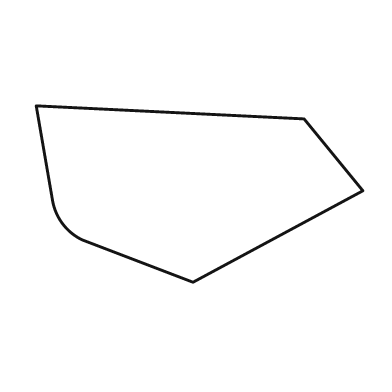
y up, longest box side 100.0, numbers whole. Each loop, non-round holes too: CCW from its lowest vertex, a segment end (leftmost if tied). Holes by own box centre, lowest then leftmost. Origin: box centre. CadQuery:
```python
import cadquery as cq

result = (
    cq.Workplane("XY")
    .moveTo(-2.0, -27.0)
    .lineTo(50.0, 1.0)
    .lineTo(32.0, 23.0)
    .lineTo(-50.0, 27.0)
    .lineTo(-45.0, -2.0)
    .threePointArc((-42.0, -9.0), (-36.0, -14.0))
    .close()
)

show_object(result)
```